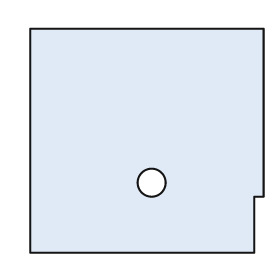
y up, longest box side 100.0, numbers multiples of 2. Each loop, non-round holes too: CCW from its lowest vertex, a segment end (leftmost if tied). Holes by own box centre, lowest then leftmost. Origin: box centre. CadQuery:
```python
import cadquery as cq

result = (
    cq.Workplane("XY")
    .moveTo(-50.0, -48.0)
    .lineTo(46.0, -48.0)
    .lineTo(46.0, -24.0)
    .lineTo(50.0, -24.0)
    .lineTo(50.0, 48.0)
    .lineTo(-50.0, 48.0)
    .close()
    .moveTo(2.0, -18.0)
    .circle(6.0)
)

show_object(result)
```